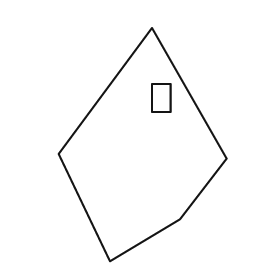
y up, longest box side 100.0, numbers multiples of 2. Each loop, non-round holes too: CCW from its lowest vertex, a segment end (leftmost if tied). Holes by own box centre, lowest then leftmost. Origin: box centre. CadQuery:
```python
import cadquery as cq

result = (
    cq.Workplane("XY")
    .moveTo(-14.0, -50.0)
    .lineTo(16.0, -32.0)
    .lineTo(36.0, -6.0)
    .lineTo(4.0, 50.0)
    .lineTo(-36.0, -4.0)
    .close()
    .moveTo(4.0, 14.0)
    .lineTo(12.0, 14.0)
    .lineTo(12.0, 26.0)
    .lineTo(4.0, 26.0)
    .close()
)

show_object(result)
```